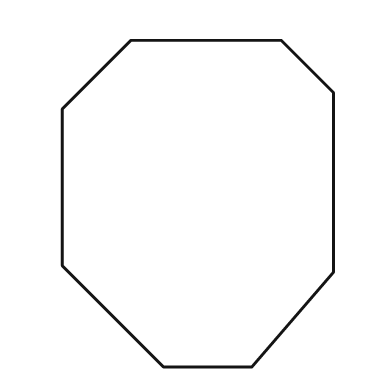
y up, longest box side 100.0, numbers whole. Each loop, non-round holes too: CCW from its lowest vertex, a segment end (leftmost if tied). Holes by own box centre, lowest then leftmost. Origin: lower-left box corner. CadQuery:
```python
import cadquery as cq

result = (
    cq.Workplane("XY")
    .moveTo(31.0, 0.0)
    .lineTo(58.0, 0.0)
    .lineTo(83.0, 29.0)
    .lineTo(83.0, 84.0)
    .lineTo(67.0, 100.0)
    .lineTo(21.0, 100.0)
    .lineTo(0.0, 79.0)
    .lineTo(0.0, 31.0)
    .close()
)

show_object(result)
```